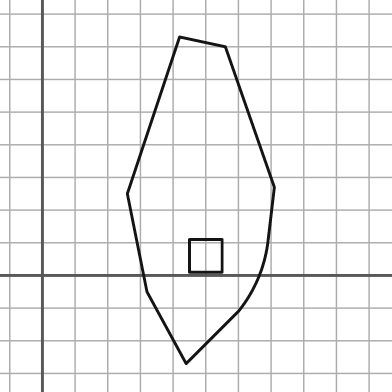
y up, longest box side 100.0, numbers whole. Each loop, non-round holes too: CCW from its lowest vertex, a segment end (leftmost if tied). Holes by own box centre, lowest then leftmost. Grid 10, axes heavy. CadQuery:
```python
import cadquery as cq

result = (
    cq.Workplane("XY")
    .moveTo(44.0, -27.0)
    .lineTo(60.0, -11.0)
    .threePointArc((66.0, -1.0), (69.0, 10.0))
    .lineTo(71.0, 27.0)
    .lineTo(56.0, 70.0)
    .lineTo(42.0, 73.0)
    .lineTo(26.0, 25.0)
    .lineTo(32.0, -5.0)
    .close()
    .moveTo(45.0, 1.0)
    .lineTo(55.0, 1.0)
    .lineTo(55.0, 11.0)
    .lineTo(45.0, 11.0)
    .close()
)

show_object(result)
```